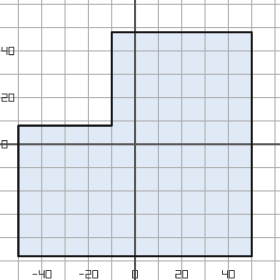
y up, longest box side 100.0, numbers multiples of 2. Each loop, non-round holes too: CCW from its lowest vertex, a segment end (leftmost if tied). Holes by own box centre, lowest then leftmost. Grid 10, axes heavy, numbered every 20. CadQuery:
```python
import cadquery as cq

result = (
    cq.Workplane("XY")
    .moveTo(-50.0, -48.0)
    .lineTo(50.0, -48.0)
    .lineTo(50.0, 48.0)
    .lineTo(-10.0, 48.0)
    .lineTo(-10.0, 8.0)
    .lineTo(-50.0, 8.0)
    .close()
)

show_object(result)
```